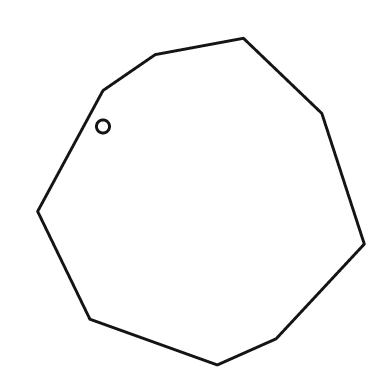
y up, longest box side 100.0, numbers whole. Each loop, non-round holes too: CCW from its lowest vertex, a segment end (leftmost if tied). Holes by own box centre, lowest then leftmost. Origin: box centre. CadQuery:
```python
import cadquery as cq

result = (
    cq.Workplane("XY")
    .moveTo(5.0, -50.0)
    .lineTo(23.0, -42.0)
    .lineTo(50.0, -13.0)
    .lineTo(37.0, 27.0)
    .lineTo(13.0, 50.0)
    .lineTo(-14.0, 45.0)
    .lineTo(-30.0, 34.0)
    .lineTo(-50.0, -3.0)
    .lineTo(-34.0, -36.0)
    .close()
    .moveTo(-30.0, 23.0)
    .circle(2.0)
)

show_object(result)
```